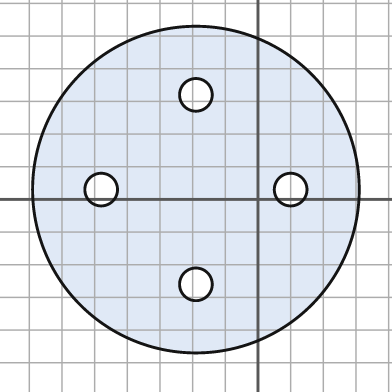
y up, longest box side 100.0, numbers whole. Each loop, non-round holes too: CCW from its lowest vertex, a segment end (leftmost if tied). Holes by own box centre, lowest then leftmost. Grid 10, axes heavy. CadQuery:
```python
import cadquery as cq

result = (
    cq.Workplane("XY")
    .moveTo(-19.0, 3.0)
    .circle(50.0)
    .moveTo(-19.0, -26.0)
    .circle(5.0)
    .moveTo(-48.0, 3.0)
    .circle(5.0)
    .moveTo(10.0, 3.0)
    .circle(5.0)
    .moveTo(-19.0, 32.0)
    .circle(5.0)
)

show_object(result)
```